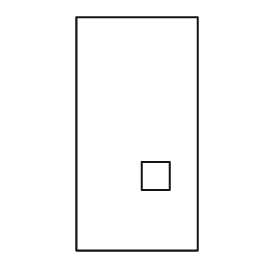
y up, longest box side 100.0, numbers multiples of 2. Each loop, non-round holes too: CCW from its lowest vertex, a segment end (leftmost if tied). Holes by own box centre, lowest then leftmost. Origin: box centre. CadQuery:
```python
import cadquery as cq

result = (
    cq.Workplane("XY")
    .moveTo(-26.0, -50.0)
    .lineTo(26.0, -50.0)
    .lineTo(26.0, 50.0)
    .lineTo(-26.0, 50.0)
    .close()
    .moveTo(2.0, -24.0)
    .lineTo(14.0, -24.0)
    .lineTo(14.0, -12.0)
    .lineTo(2.0, -12.0)
    .close()
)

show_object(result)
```